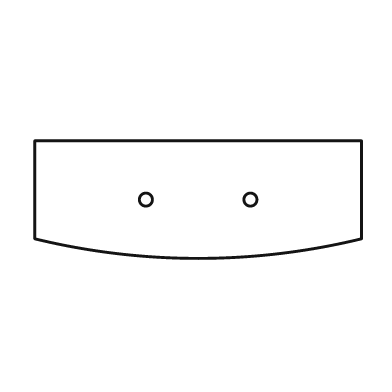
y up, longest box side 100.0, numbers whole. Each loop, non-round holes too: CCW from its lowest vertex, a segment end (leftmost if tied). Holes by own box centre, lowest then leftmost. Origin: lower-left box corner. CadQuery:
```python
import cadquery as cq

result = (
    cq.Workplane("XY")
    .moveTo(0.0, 6.0)
    .threePointArc((50.0, 0.0), (100.0, 6.0))
    .lineTo(100.0, 36.0)
    .lineTo(0.0, 36.0)
    .close()
    .moveTo(34.0, 18.0)
    .circle(2.0)
    .moveTo(66.0, 18.0)
    .circle(2.0)
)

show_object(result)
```